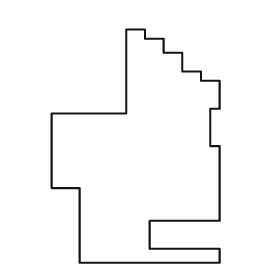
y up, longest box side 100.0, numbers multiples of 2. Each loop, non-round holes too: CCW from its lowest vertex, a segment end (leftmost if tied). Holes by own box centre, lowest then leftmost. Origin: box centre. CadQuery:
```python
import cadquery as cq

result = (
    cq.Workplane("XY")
    .moveTo(-24.0, -50.0)
    .lineTo(36.0, -50.0)
    .lineTo(36.0, -44.0)
    .lineTo(6.0, -44.0)
    .lineTo(6.0, -32.0)
    .lineTo(36.0, -32.0)
    .lineTo(36.0, 0.0)
    .lineTo(32.0, 0.0)
    .lineTo(32.0, 16.0)
    .lineTo(36.0, 16.0)
    .lineTo(36.0, 28.0)
    .lineTo(28.0, 28.0)
    .lineTo(28.0, 32.0)
    .lineTo(20.0, 32.0)
    .lineTo(20.0, 40.0)
    .lineTo(12.0, 40.0)
    .lineTo(12.0, 46.0)
    .lineTo(4.0, 46.0)
    .lineTo(4.0, 50.0)
    .lineTo(-4.0, 50.0)
    .lineTo(-4.0, 14.0)
    .lineTo(-36.0, 14.0)
    .lineTo(-36.0, -18.0)
    .lineTo(-24.0, -18.0)
    .close()
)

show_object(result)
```